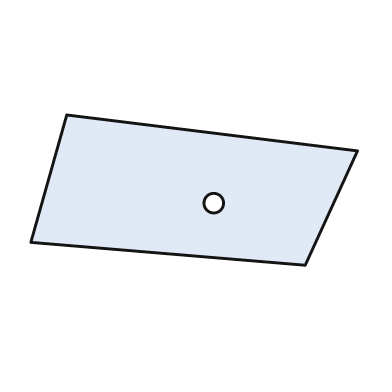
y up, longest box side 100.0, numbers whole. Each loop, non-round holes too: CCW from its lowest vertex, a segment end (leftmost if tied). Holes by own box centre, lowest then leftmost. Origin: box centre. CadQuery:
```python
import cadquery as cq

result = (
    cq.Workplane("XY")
    .moveTo(34.0, -23.0)
    .lineTo(50.0, 12.0)
    .lineTo(-39.0, 23.0)
    .lineTo(-50.0, -16.0)
    .close()
    .moveTo(6.0, -4.0)
    .circle(3.0)
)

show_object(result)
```